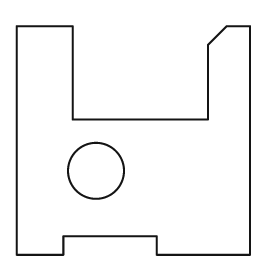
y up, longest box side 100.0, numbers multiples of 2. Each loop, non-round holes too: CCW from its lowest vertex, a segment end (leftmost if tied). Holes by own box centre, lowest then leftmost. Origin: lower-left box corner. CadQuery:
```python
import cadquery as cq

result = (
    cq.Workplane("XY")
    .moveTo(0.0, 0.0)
    .lineTo(20.0, 0.0)
    .lineTo(20.0, 8.0)
    .lineTo(60.0, 8.0)
    .lineTo(60.0, 0.0)
    .lineTo(100.0, 0.0)
    .lineTo(100.0, 98.0)
    .lineTo(90.0, 98.0)
    .lineTo(82.0, 90.0)
    .lineTo(82.0, 58.0)
    .lineTo(24.0, 58.0)
    .lineTo(24.0, 98.0)
    .lineTo(0.0, 98.0)
    .close()
    .moveTo(34.0, 36.0)
    .circle(12.0)
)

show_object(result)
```